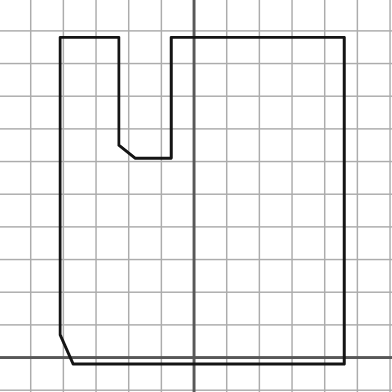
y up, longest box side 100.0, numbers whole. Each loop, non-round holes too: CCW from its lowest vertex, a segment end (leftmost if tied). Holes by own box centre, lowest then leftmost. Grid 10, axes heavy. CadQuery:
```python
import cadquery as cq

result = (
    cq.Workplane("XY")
    .moveTo(-37.0, -2.0)
    .lineTo(46.0, -2.0)
    .lineTo(46.0, 98.0)
    .lineTo(-7.0, 98.0)
    .lineTo(-7.0, 61.0)
    .lineTo(-18.0, 61.0)
    .lineTo(-23.0, 65.0)
    .lineTo(-23.0, 98.0)
    .lineTo(-41.0, 98.0)
    .lineTo(-41.0, 7.0)
    .close()
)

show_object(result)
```